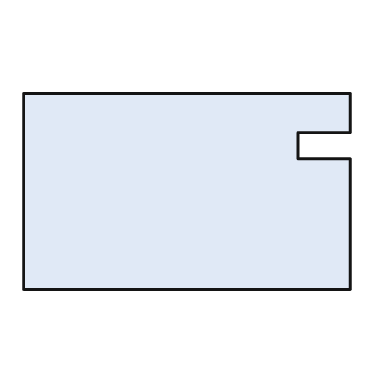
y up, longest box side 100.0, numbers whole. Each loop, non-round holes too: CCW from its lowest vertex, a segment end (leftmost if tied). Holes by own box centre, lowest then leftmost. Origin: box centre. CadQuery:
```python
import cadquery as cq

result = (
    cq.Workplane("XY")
    .moveTo(-50.0, -30.0)
    .lineTo(50.0, -30.0)
    .lineTo(50.0, 10.0)
    .lineTo(34.0, 10.0)
    .lineTo(34.0, 18.0)
    .lineTo(50.0, 18.0)
    .lineTo(50.0, 30.0)
    .lineTo(-50.0, 30.0)
    .close()
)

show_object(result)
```